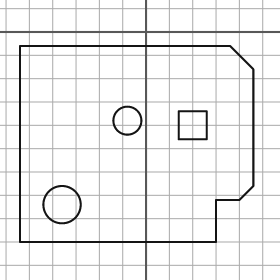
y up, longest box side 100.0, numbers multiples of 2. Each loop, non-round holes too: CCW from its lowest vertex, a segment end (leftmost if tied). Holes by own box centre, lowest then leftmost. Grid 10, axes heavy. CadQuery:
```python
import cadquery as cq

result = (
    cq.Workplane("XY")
    .moveTo(-54.0, -90.0)
    .lineTo(30.0, -90.0)
    .lineTo(30.0, -72.0)
    .lineTo(40.0, -72.0)
    .lineTo(46.0, -66.0)
    .lineTo(46.0, -16.0)
    .lineTo(36.0, -6.0)
    .lineTo(-54.0, -6.0)
    .close()
    .moveTo(-36.0, -74.0)
    .circle(8.0)
    .moveTo(14.0, -46.0)
    .lineTo(26.0, -46.0)
    .lineTo(26.0, -34.0)
    .lineTo(14.0, -34.0)
    .close()
    .moveTo(-8.0, -38.0)
    .circle(6.0)
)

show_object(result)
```